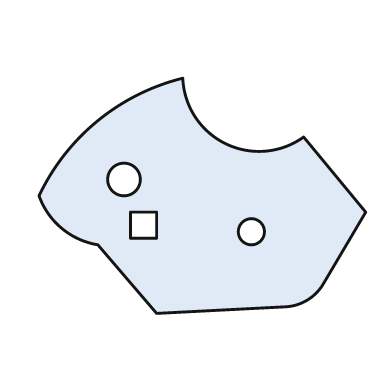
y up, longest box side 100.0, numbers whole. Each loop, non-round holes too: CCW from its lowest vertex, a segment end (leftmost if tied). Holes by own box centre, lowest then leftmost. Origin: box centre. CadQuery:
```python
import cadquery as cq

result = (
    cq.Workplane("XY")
    .moveTo(-14.0, -36.0)
    .lineTo(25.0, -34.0)
    .threePointArc((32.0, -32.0), (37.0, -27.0))
    .lineTo(50.0, -5.0)
    .lineTo(31.0, 18.0)
    .threePointArc((7.0, 16.0), (-6.0, 36.0))
    .threePointArc((-32.0, 23.0), (-50.0, 0.0))
    .threePointArc((-43.0, -10.0), (-32.0, -15.0))
    .close()
    .moveTo(15.0, -11.0)
    .circle(4.0)
    .moveTo(-22.0, -13.0)
    .lineTo(-14.0, -13.0)
    .lineTo(-14.0, -5.0)
    .lineTo(-22.0, -5.0)
    .close()
    .moveTo(-24.0, 5.0)
    .circle(5.0)
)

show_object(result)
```